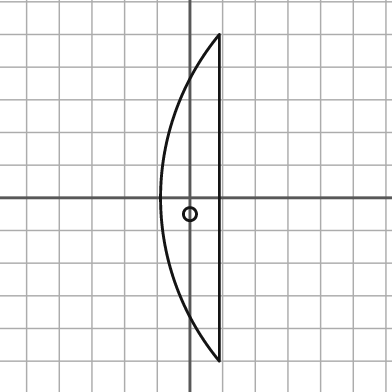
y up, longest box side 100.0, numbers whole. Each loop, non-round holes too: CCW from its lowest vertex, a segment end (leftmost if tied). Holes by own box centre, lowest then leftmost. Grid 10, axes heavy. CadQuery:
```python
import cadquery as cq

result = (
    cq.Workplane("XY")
    .moveTo(9.0, -50.0)
    .lineTo(9.0, 50.0)
    .threePointArc((-9.0, 0.0), (9.0, -50.0))
    .close()
    .moveTo(0.0, -5.0)
    .circle(2.0)
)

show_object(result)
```